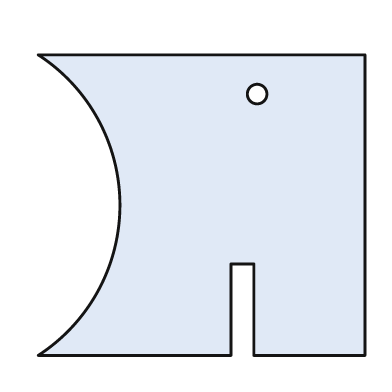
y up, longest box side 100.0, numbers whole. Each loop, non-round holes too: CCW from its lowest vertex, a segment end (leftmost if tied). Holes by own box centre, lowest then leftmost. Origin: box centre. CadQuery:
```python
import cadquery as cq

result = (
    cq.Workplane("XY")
    .moveTo(-50.0, -46.0)
    .lineTo(9.0, -46.0)
    .lineTo(9.0, -18.0)
    .lineTo(16.0, -18.0)
    .lineTo(16.0, -46.0)
    .lineTo(50.0, -46.0)
    .lineTo(50.0, 46.0)
    .lineTo(-50.0, 46.0)
    .threePointArc((-25.0, 0.0), (-50.0, -46.0))
    .close()
    .moveTo(17.0, 34.0)
    .circle(3.0)
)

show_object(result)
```